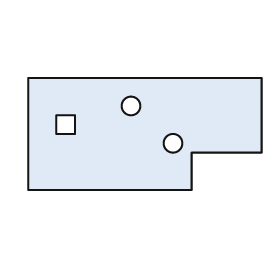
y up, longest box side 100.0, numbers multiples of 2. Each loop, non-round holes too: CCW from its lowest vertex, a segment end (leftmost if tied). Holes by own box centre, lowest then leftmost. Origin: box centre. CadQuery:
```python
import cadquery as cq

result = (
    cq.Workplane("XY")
    .moveTo(-50.0, -24.0)
    .lineTo(20.0, -24.0)
    .lineTo(20.0, -8.0)
    .lineTo(50.0, -8.0)
    .lineTo(50.0, 24.0)
    .lineTo(-50.0, 24.0)
    .close()
    .moveTo(12.0, -4.0)
    .circle(4.0)
    .moveTo(-38.0, 0.0)
    .lineTo(-30.0, 0.0)
    .lineTo(-30.0, 8.0)
    .lineTo(-38.0, 8.0)
    .close()
    .moveTo(-6.0, 12.0)
    .circle(4.0)
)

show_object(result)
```